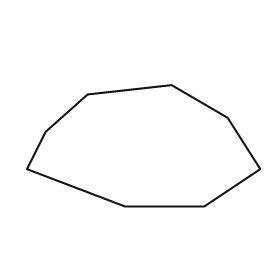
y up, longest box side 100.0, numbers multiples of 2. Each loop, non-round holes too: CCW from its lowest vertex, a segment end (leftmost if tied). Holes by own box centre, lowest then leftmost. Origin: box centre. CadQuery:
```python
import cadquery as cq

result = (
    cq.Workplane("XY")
    .moveTo(-8.0, -26.0)
    .lineTo(26.0, -26.0)
    .lineTo(50.0, -10.0)
    .lineTo(36.0, 12.0)
    .lineTo(12.0, 26.0)
    .lineTo(-24.0, 22.0)
    .lineTo(-42.0, 6.0)
    .lineTo(-50.0, -10.0)
    .close()
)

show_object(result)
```